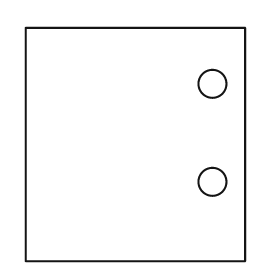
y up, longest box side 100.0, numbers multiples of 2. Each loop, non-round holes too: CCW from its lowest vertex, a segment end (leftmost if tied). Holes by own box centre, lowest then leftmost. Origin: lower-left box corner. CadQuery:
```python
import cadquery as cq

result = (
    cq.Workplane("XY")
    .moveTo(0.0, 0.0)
    .lineTo(94.0, 0.0)
    .lineTo(94.0, 100.0)
    .lineTo(0.0, 100.0)
    .close()
    .moveTo(80.0, 34.0)
    .circle(6.0)
    .moveTo(80.0, 76.0)
    .circle(6.0)
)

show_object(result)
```